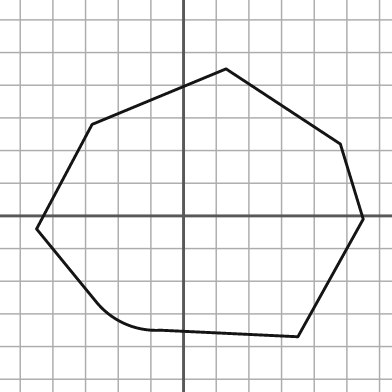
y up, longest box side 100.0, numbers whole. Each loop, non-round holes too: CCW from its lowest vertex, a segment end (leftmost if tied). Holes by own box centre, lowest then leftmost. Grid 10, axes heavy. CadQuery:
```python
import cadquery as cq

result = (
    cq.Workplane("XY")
    .moveTo(35.0, -37.0)
    .lineTo(55.0, -1.0)
    .lineTo(48.0, 22.0)
    .lineTo(13.0, 45.0)
    .lineTo(-28.0, 28.0)
    .lineTo(-45.0, -4.0)
    .lineTo(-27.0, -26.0)
    .threePointArc((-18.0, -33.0), (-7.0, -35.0))
    .close()
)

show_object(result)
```